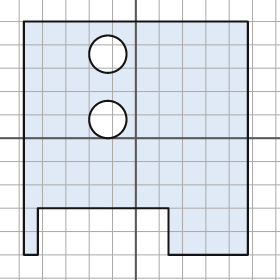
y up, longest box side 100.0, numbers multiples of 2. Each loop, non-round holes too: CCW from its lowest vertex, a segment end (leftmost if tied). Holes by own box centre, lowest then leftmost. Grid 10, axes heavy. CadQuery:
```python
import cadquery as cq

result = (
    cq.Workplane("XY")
    .moveTo(-48.0, -50.0)
    .lineTo(-42.0, -50.0)
    .lineTo(-42.0, -30.0)
    .lineTo(14.0, -30.0)
    .lineTo(14.0, -50.0)
    .lineTo(48.0, -50.0)
    .lineTo(48.0, 50.0)
    .lineTo(-48.0, 50.0)
    .close()
    .moveTo(-12.0, 8.0)
    .circle(8.0)
    .moveTo(-12.0, 36.0)
    .circle(8.0)
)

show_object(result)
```